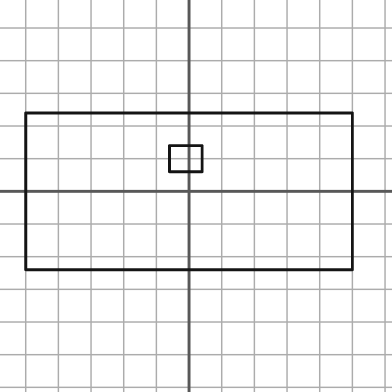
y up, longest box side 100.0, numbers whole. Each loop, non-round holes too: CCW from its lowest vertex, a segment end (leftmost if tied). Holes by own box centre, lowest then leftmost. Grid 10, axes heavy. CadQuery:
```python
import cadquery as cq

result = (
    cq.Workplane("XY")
    .moveTo(-50.0, -24.0)
    .lineTo(50.0, -24.0)
    .lineTo(50.0, 24.0)
    .lineTo(-50.0, 24.0)
    .close()
    .moveTo(-6.0, 6.0)
    .lineTo(4.0, 6.0)
    .lineTo(4.0, 14.0)
    .lineTo(-6.0, 14.0)
    .close()
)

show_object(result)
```